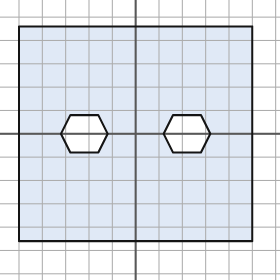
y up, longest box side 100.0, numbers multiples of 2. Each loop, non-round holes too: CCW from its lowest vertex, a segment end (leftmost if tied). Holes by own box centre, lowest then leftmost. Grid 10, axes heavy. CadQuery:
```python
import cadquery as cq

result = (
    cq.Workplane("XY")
    .moveTo(-50.0, -46.0)
    .lineTo(50.0, -46.0)
    .lineTo(50.0, 46.0)
    .lineTo(-50.0, 46.0)
    .close()
    .moveTo(-28.0, -8.0)
    .lineTo(-16.0, -8.0)
    .lineTo(-12.0, 0.0)
    .lineTo(-16.0, 8.0)
    .lineTo(-28.0, 8.0)
    .lineTo(-32.0, 0.0)
    .close()
    .moveTo(16.0, -8.0)
    .lineTo(28.0, -8.0)
    .lineTo(32.0, 0.0)
    .lineTo(28.0, 8.0)
    .lineTo(16.0, 8.0)
    .lineTo(12.0, 0.0)
    .close()
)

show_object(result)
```